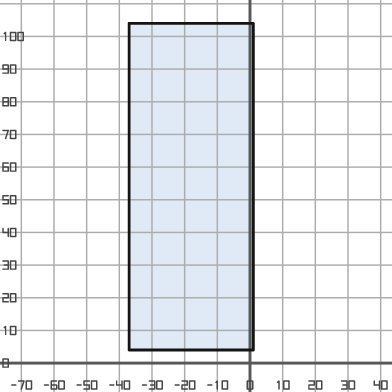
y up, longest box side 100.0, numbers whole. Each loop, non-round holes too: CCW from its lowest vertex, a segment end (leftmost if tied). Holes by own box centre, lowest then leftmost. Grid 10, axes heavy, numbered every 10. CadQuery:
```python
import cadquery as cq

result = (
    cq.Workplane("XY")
    .moveTo(-37.0, 4.0)
    .lineTo(1.0, 4.0)
    .lineTo(1.0, 104.0)
    .lineTo(-37.0, 104.0)
    .close()
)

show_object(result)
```